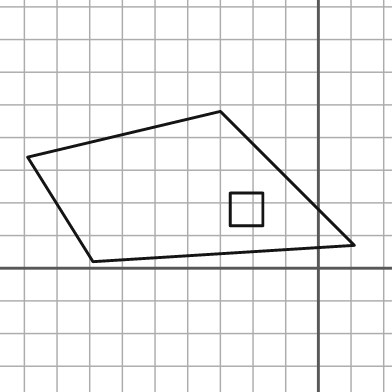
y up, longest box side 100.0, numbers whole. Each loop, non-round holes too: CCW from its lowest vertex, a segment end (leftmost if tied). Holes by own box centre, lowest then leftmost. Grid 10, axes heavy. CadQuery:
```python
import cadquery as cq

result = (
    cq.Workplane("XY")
    .moveTo(-69.0, 2.0)
    .lineTo(11.0, 7.0)
    .lineTo(-30.0, 48.0)
    .lineTo(-89.0, 34.0)
    .close()
    .moveTo(-27.0, 13.0)
    .lineTo(-17.0, 13.0)
    .lineTo(-17.0, 23.0)
    .lineTo(-27.0, 23.0)
    .close()
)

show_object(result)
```